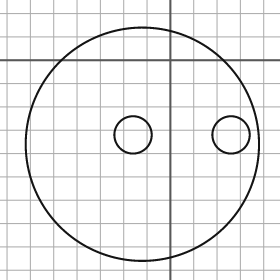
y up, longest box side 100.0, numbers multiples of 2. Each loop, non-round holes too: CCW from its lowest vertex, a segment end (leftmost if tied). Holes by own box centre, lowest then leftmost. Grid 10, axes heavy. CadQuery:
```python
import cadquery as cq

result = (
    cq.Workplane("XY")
    .moveTo(-12.0, -36.0)
    .circle(50.0)
    .moveTo(-16.0, -32.0)
    .circle(8.0)
    .moveTo(26.0, -32.0)
    .circle(8.0)
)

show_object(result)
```